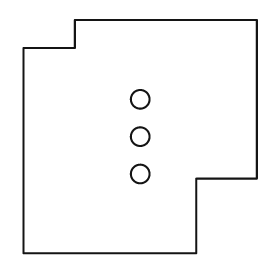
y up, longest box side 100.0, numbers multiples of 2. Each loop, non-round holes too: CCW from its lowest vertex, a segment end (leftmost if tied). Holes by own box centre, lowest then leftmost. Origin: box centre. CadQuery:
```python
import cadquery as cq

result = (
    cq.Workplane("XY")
    .moveTo(-50.0, -50.0)
    .lineTo(24.0, -50.0)
    .lineTo(24.0, -18.0)
    .lineTo(50.0, -18.0)
    .lineTo(50.0, 50.0)
    .lineTo(-28.0, 50.0)
    .lineTo(-28.0, 38.0)
    .lineTo(-50.0, 38.0)
    .close()
    .moveTo(0.0, -16.0)
    .circle(4.0)
    .moveTo(0.0, 0.0)
    .circle(4.0)
    .moveTo(0.0, 16.0)
    .circle(4.0)
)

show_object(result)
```